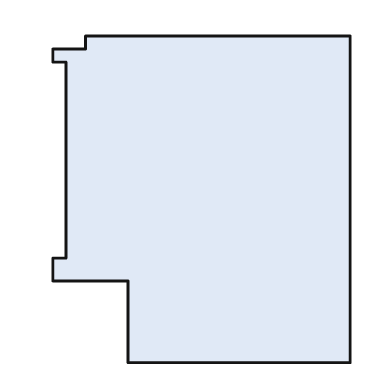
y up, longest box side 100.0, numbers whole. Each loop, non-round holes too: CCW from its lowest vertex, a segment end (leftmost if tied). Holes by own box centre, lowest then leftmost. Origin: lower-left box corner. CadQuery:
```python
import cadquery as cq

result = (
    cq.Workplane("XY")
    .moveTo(23.0, 0.0)
    .lineTo(91.0, 0.0)
    .lineTo(91.0, 100.0)
    .lineTo(10.0, 100.0)
    .lineTo(10.0, 96.0)
    .lineTo(0.0, 96.0)
    .lineTo(0.0, 92.0)
    .lineTo(4.0, 92.0)
    .lineTo(4.0, 32.0)
    .lineTo(0.0, 32.0)
    .lineTo(0.0, 25.0)
    .lineTo(23.0, 25.0)
    .close()
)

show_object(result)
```